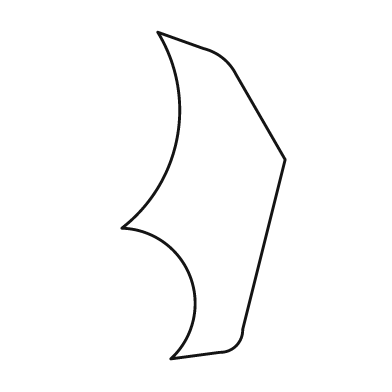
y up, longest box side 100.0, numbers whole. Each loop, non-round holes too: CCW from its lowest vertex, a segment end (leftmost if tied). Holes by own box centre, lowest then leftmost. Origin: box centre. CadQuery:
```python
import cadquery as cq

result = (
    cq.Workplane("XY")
    .moveTo(-10.0, -50.0)
    .lineTo(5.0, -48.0)
    .threePointArc((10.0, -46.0), (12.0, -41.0))
    .lineTo(25.0, 11.0)
    .lineTo(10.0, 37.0)
    .threePointArc((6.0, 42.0), (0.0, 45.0))
    .lineTo(-14.0, 50.0)
    .threePointArc((-8.0, 18.0), (-25.0, -10.0))
    .threePointArc((-4.0, -25.0), (-10.0, -50.0))
    .close()
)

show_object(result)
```